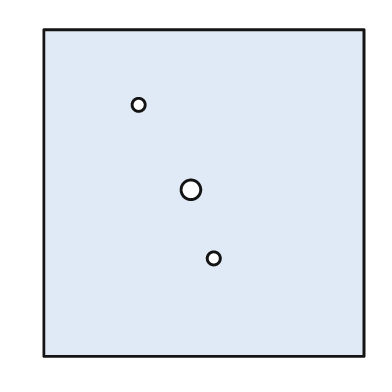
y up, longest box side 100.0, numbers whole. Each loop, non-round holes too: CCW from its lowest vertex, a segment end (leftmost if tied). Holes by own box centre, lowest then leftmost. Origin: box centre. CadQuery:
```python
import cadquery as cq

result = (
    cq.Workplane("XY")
    .moveTo(-49.0, -50.0)
    .lineTo(49.0, -50.0)
    .lineTo(49.0, 50.0)
    .lineTo(-49.0, 50.0)
    .close()
    .moveTo(3.0, -20.0)
    .circle(2.0)
    .moveTo(-4.0, 1.0)
    .circle(3.0)
    .moveTo(-20.0, 27.0)
    .circle(2.0)
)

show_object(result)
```